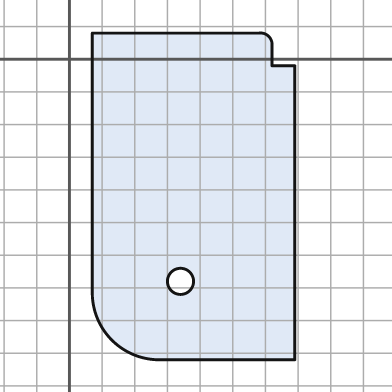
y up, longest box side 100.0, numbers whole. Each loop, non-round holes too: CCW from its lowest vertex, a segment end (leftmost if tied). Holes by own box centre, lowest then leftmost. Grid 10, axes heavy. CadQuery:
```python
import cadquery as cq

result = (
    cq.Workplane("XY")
    .moveTo(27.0, -92.0)
    .lineTo(69.0, -92.0)
    .lineTo(69.0, -2.0)
    .lineTo(62.0, -2.0)
    .lineTo(62.0, 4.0)
    .threePointArc((61.0, 7.0), (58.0, 8.0))
    .lineTo(7.0, 8.0)
    .lineTo(7.0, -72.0)
    .threePointArc((13.0, -86.0), (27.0, -92.0))
    .close()
    .moveTo(34.0, -68.0)
    .circle(4.0)
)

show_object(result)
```